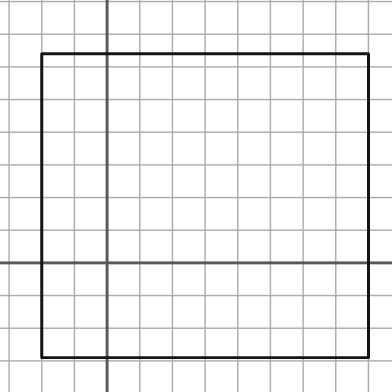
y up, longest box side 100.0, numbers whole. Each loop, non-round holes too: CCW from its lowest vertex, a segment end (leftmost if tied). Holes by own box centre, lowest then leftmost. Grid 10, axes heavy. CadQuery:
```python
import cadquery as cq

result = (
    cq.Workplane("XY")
    .moveTo(-20.0, -29.0)
    .lineTo(80.0, -29.0)
    .lineTo(80.0, 64.0)
    .lineTo(-20.0, 64.0)
    .close()
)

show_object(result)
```